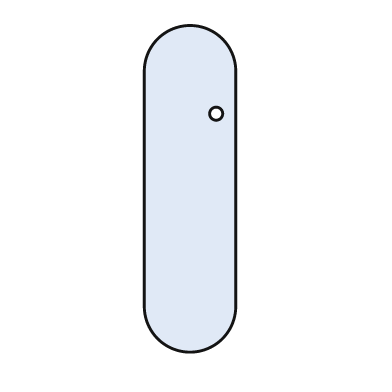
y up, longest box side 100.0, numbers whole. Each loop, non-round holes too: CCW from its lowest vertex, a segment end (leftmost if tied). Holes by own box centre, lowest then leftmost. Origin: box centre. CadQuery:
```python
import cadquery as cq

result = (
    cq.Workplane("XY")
    .moveTo(-14.0, -36.0)
    .threePointArc((0.0, -50.0), (14.0, -36.0))
    .lineTo(14.0, 36.0)
    .threePointArc((0.0, 50.0), (-14.0, 36.0))
    .close()
    .moveTo(8.0, 23.0)
    .circle(2.0)
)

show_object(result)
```